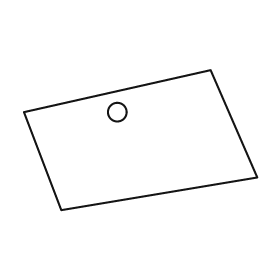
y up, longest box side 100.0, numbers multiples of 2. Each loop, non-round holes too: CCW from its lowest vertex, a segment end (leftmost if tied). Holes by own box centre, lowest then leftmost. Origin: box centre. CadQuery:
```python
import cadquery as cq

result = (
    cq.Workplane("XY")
    .moveTo(-34.0, -30.0)
    .lineTo(50.0, -16.0)
    .lineTo(30.0, 30.0)
    .lineTo(-50.0, 12.0)
    .close()
    .moveTo(-10.0, 12.0)
    .circle(4.0)
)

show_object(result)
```